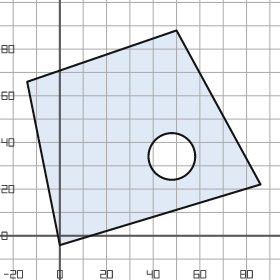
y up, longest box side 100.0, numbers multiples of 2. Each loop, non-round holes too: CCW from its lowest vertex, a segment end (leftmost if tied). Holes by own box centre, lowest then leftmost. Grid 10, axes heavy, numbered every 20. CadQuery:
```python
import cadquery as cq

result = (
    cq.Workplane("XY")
    .moveTo(0.0, -4.0)
    .lineTo(86.0, 22.0)
    .lineTo(50.0, 88.0)
    .lineTo(-14.0, 66.0)
    .close()
    .moveTo(48.0, 34.0)
    .circle(10.0)
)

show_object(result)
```